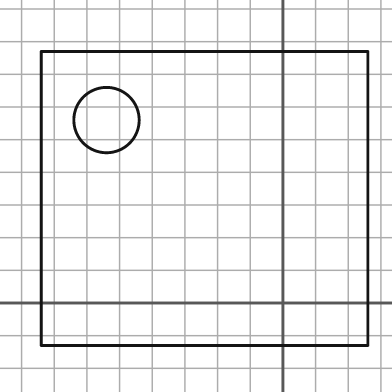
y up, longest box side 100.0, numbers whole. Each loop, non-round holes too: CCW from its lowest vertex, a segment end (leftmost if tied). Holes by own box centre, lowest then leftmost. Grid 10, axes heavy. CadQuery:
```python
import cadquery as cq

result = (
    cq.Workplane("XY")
    .moveTo(-74.0, -13.0)
    .lineTo(26.0, -13.0)
    .lineTo(26.0, 77.0)
    .lineTo(-74.0, 77.0)
    .close()
    .moveTo(-54.0, 56.0)
    .circle(10.0)
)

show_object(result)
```